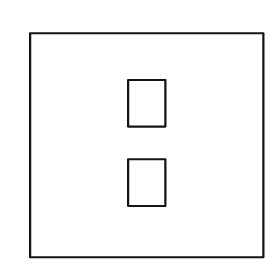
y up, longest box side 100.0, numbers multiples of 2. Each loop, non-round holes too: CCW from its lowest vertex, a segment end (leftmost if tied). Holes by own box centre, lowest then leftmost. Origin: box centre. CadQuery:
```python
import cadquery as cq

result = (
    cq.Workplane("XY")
    .moveTo(-50.0, -48.0)
    .lineTo(50.0, -48.0)
    .lineTo(50.0, 48.0)
    .lineTo(-50.0, 48.0)
    .close()
    .moveTo(-8.0, -26.0)
    .lineTo(8.0, -26.0)
    .lineTo(8.0, -6.0)
    .lineTo(-8.0, -6.0)
    .close()
    .moveTo(-8.0, 8.0)
    .lineTo(8.0, 8.0)
    .lineTo(8.0, 28.0)
    .lineTo(-8.0, 28.0)
    .close()
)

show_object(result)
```